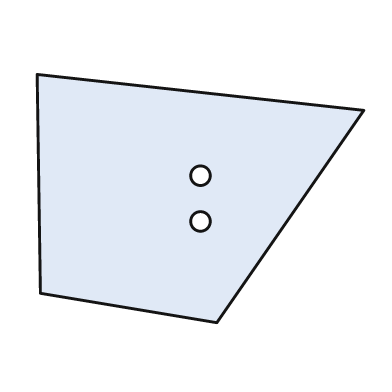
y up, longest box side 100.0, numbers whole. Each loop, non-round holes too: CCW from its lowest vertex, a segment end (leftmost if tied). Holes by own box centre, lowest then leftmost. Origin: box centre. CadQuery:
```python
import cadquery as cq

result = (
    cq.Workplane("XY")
    .moveTo(5.0, -38.0)
    .lineTo(50.0, 27.0)
    .lineTo(-50.0, 38.0)
    .lineTo(-49.0, -29.0)
    .close()
    .moveTo(0.0, -7.0)
    .circle(3.0)
    .moveTo(0.0, 7.0)
    .circle(3.0)
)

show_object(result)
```